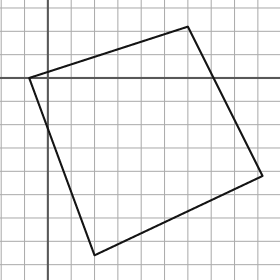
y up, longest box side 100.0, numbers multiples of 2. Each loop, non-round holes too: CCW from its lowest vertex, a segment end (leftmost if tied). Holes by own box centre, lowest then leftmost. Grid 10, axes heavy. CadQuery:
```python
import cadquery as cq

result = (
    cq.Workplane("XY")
    .moveTo(20.0, -76.0)
    .lineTo(92.0, -42.0)
    .lineTo(60.0, 22.0)
    .lineTo(-8.0, 0.0)
    .close()
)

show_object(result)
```